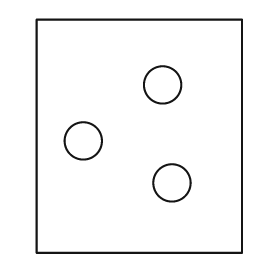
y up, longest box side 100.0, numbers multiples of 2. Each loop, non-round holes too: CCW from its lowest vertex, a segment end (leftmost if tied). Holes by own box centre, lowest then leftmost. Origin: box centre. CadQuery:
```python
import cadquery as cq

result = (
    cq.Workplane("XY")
    .moveTo(-44.0, -50.0)
    .lineTo(44.0, -50.0)
    .lineTo(44.0, 50.0)
    .lineTo(-44.0, 50.0)
    .close()
    .moveTo(14.0, -20.0)
    .circle(8.0)
    .moveTo(-24.0, -2.0)
    .circle(8.0)
    .moveTo(10.0, 22.0)
    .circle(8.0)
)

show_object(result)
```